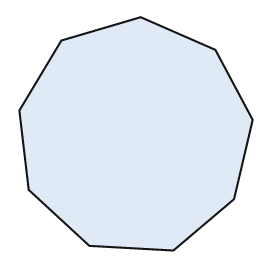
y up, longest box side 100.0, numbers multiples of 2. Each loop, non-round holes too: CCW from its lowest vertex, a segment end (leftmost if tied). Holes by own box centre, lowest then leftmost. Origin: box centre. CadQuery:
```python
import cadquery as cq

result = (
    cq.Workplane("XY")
    .moveTo(16.0, -50.0)
    .lineTo(42.0, -28.0)
    .lineTo(50.0, 6.0)
    .lineTo(34.0, 36.0)
    .lineTo(2.0, 50.0)
    .lineTo(-32.0, 40.0)
    .lineTo(-50.0, 10.0)
    .lineTo(-46.0, -24.0)
    .lineTo(-20.0, -48.0)
    .close()
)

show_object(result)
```